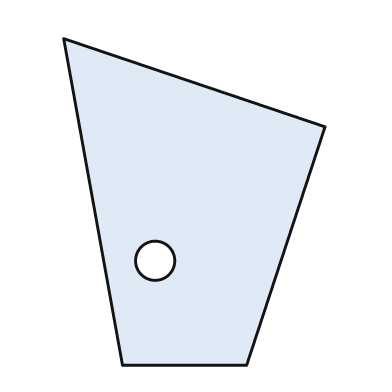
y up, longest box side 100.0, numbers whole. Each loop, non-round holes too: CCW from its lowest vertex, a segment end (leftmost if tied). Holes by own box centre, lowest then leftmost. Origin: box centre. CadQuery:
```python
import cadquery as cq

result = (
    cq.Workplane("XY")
    .moveTo(-22.0, -50.0)
    .lineTo(16.0, -50.0)
    .lineTo(40.0, 23.0)
    .lineTo(-40.0, 50.0)
    .close()
    .moveTo(-12.0, -18.0)
    .circle(6.0)
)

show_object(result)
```